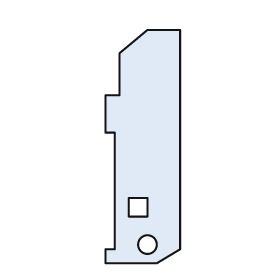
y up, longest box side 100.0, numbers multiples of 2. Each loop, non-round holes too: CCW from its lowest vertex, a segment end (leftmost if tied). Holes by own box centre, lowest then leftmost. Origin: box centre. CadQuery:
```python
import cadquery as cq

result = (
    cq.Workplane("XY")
    .moveTo(-16.0, -50.0)
    .lineTo(6.0, -50.0)
    .lineTo(16.0, -44.0)
    .lineTo(16.0, 50.0)
    .lineTo(2.0, 50.0)
    .lineTo(-10.0, 40.0)
    .lineTo(-10.0, 22.0)
    .lineTo(-16.0, 22.0)
    .lineTo(-16.0, 6.0)
    .lineTo(-12.0, 6.0)
    .lineTo(-12.0, -44.0)
    .lineTo(-16.0, -44.0)
    .close()
    .moveTo(2.0, -42.0)
    .circle(4.0)
    .moveTo(-6.0, -30.0)
    .lineTo(2.0, -30.0)
    .lineTo(2.0, -22.0)
    .lineTo(-6.0, -22.0)
    .close()
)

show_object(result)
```